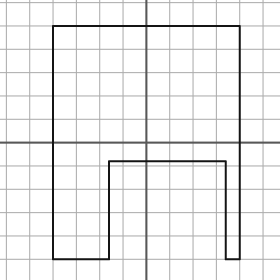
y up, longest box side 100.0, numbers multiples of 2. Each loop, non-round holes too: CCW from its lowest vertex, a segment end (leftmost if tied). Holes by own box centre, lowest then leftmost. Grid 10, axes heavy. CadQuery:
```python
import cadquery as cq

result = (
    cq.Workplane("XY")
    .moveTo(-40.0, -50.0)
    .lineTo(-16.0, -50.0)
    .lineTo(-16.0, -8.0)
    .lineTo(34.0, -8.0)
    .lineTo(34.0, -50.0)
    .lineTo(40.0, -50.0)
    .lineTo(40.0, 50.0)
    .lineTo(-40.0, 50.0)
    .close()
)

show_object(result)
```